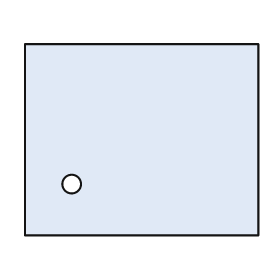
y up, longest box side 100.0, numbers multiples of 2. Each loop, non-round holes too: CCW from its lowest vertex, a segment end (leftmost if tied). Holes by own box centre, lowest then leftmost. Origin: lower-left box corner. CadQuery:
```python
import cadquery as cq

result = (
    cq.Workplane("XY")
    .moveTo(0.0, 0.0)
    .lineTo(100.0, 0.0)
    .lineTo(100.0, 82.0)
    .lineTo(0.0, 82.0)
    .close()
    .moveTo(20.0, 22.0)
    .circle(4.0)
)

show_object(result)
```